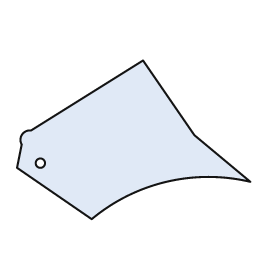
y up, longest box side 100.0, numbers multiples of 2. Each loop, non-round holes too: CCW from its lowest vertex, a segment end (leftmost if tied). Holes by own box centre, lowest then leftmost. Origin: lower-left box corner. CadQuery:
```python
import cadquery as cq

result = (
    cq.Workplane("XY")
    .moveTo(32.0, 0.0)
    .threePointArc((64.0, 16.0), (100.0, 16.0))
    .lineTo(76.0, 36.0)
    .lineTo(54.0, 68.0)
    .lineTo(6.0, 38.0)
    .threePointArc((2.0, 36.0), (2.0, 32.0))
    .lineTo(0.0, 22.0)
    .close()
    .moveTo(10.0, 24.0)
    .circle(2.0)
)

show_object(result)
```